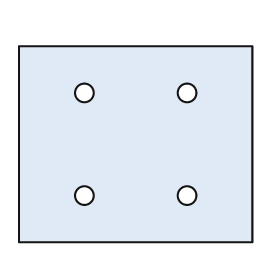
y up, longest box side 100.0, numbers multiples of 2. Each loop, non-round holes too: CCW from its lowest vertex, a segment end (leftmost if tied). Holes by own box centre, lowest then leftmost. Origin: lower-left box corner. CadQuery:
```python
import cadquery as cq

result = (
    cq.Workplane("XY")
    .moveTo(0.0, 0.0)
    .lineTo(100.0, 0.0)
    .lineTo(100.0, 84.0)
    .lineTo(0.0, 84.0)
    .close()
    .moveTo(28.0, 20.0)
    .circle(4.0)
    .moveTo(72.0, 20.0)
    .circle(4.0)
    .moveTo(28.0, 64.0)
    .circle(4.0)
    .moveTo(72.0, 64.0)
    .circle(4.0)
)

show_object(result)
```